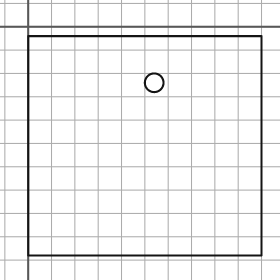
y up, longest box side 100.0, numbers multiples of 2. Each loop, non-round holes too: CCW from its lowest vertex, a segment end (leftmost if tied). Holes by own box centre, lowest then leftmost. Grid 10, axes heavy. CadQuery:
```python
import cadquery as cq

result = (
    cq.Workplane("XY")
    .moveTo(0.0, -98.0)
    .lineTo(100.0, -98.0)
    .lineTo(100.0, -4.0)
    .lineTo(0.0, -4.0)
    .close()
    .moveTo(54.0, -24.0)
    .circle(4.0)
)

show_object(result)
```